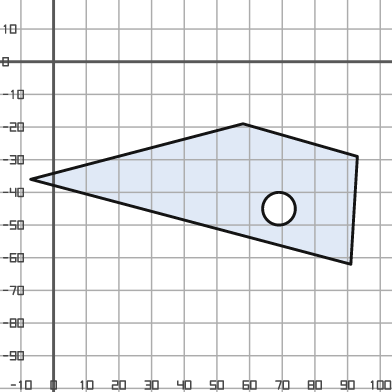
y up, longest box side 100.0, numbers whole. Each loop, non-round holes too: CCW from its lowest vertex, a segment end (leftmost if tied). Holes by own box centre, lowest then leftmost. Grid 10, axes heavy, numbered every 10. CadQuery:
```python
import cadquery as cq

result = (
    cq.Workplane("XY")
    .moveTo(91.0, -62.0)
    .lineTo(93.0, -29.0)
    .lineTo(58.0, -19.0)
    .lineTo(-7.0, -36.0)
    .close()
    .moveTo(69.0, -45.0)
    .circle(5.0)
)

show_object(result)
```